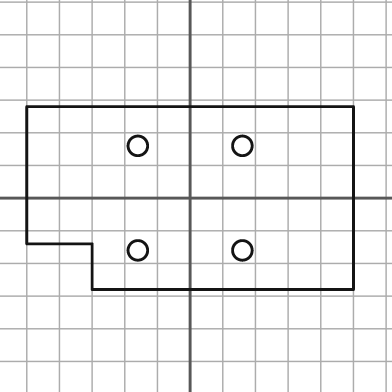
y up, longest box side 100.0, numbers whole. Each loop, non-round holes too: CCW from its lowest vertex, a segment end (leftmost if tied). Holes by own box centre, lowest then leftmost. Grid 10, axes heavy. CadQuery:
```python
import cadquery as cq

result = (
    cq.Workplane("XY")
    .moveTo(-30.0, -28.0)
    .lineTo(50.0, -28.0)
    .lineTo(50.0, 28.0)
    .lineTo(-50.0, 28.0)
    .lineTo(-50.0, -14.0)
    .lineTo(-30.0, -14.0)
    .close()
    .moveTo(-16.0, -16.0)
    .circle(3.0)
    .moveTo(16.0, -16.0)
    .circle(3.0)
    .moveTo(-16.0, 16.0)
    .circle(3.0)
    .moveTo(16.0, 16.0)
    .circle(3.0)
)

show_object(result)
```